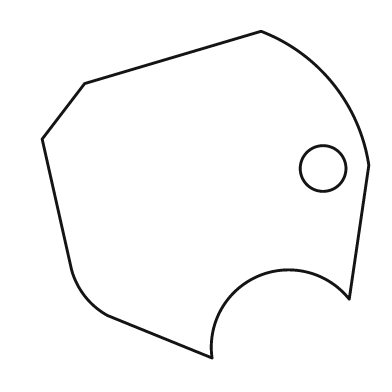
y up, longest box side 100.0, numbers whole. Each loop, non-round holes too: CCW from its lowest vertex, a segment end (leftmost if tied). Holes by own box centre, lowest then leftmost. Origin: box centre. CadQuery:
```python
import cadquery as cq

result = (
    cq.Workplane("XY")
    .moveTo(2.0, -50.0)
    .threePointArc((16.0, -25.0), (44.0, -32.0))
    .lineTo(50.0, 9.0)
    .threePointArc((39.0, 34.0), (17.0, 50.0))
    .lineTo(-37.0, 34.0)
    .lineTo(-50.0, 17.0)
    .lineTo(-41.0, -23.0)
    .threePointArc((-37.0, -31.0), (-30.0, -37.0))
    .close()
    .moveTo(36.0, 8.0)
    .circle(7.0)
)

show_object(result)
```